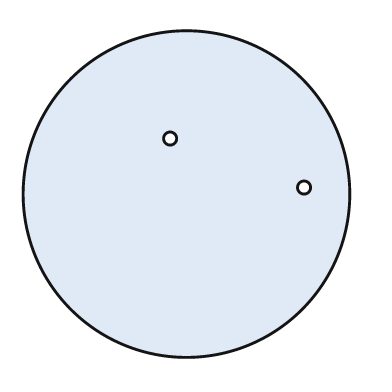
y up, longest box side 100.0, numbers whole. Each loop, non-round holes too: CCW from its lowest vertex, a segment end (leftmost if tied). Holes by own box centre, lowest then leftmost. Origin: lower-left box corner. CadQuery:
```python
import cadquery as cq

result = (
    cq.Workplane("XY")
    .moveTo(50.0, 50.0)
    .circle(50.0)
    .moveTo(86.0, 52.0)
    .circle(2.0)
    .moveTo(45.0, 67.0)
    .circle(2.0)
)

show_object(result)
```